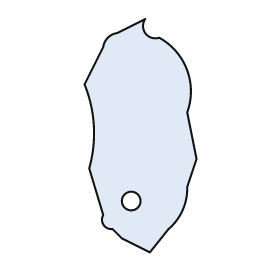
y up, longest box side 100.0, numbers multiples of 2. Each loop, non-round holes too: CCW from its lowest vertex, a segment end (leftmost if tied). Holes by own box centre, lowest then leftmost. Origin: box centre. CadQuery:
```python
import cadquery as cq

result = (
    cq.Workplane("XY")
    .moveTo(4.0, -50.0)
    .lineTo(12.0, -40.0)
    .threePointArc((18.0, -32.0), (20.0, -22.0))
    .lineTo(24.0, -10.0)
    .lineTo(20.0, 10.0)
    .threePointArc((20.0, 28.0), (8.0, 42.0))
    .threePointArc((2.0, 44.0), (2.0, 50.0))
    .lineTo(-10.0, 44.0)
    .threePointArc((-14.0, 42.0), (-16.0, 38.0))
    .lineTo(-24.0, 22.0)
    .threePointArc((-20.0, 4.0), (-22.0, -14.0))
    .lineTo(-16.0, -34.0)
    .threePointArc((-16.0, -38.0), (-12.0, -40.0))
    .lineTo(-8.0, -44.0)
    .close()
    .moveTo(-4.0, -28.0)
    .circle(4.0)
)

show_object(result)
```